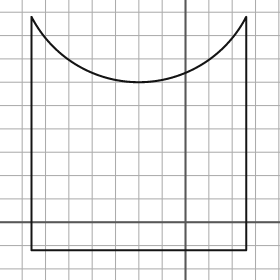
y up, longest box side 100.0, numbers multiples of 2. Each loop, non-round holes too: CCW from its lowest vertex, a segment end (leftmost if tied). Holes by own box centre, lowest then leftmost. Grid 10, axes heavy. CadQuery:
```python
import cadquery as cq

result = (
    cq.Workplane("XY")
    .moveTo(-66.0, -12.0)
    .lineTo(26.0, -12.0)
    .lineTo(26.0, 88.0)
    .threePointArc((-20.0, 60.0), (-66.0, 88.0))
    .close()
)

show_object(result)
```